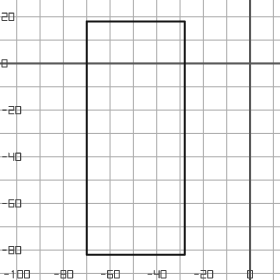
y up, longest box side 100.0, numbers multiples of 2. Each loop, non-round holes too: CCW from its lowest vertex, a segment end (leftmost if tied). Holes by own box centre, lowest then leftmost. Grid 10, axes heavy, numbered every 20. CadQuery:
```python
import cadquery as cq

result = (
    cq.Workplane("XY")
    .moveTo(-70.0, -82.0)
    .lineTo(-28.0, -82.0)
    .lineTo(-28.0, 18.0)
    .lineTo(-70.0, 18.0)
    .close()
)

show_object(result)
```